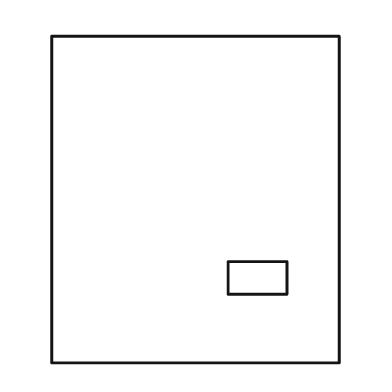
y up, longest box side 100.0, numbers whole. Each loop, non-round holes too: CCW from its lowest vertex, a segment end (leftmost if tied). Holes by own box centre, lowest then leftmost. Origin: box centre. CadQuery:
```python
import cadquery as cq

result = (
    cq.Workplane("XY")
    .moveTo(-44.0, -50.0)
    .lineTo(44.0, -50.0)
    .lineTo(44.0, 50.0)
    .lineTo(-44.0, 50.0)
    .close()
    .moveTo(10.0, -29.0)
    .lineTo(28.0, -29.0)
    .lineTo(28.0, -19.0)
    .lineTo(10.0, -19.0)
    .close()
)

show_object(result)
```